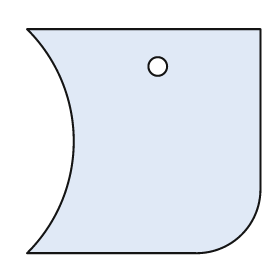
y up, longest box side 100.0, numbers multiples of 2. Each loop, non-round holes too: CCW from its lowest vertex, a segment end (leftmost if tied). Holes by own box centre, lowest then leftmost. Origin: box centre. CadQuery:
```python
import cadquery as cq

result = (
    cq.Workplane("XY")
    .moveTo(-50.0, -48.0)
    .lineTo(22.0, -48.0)
    .threePointArc((42.0, -40.0), (50.0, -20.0))
    .lineTo(50.0, 48.0)
    .lineTo(-50.0, 48.0)
    .threePointArc((-30.0, 0.0), (-50.0, -48.0))
    .close()
    .moveTo(6.0, 32.0)
    .circle(4.0)
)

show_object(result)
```